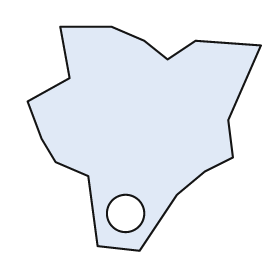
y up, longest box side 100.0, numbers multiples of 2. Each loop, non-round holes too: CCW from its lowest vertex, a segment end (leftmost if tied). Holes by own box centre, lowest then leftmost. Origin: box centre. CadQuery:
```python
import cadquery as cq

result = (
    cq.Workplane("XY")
    .moveTo(-2.0, -48.0)
    .lineTo(14.0, -24.0)
    .lineTo(26.0, -14.0)
    .lineTo(38.0, -8.0)
    .lineTo(36.0, 8.0)
    .lineTo(50.0, 40.0)
    .lineTo(22.0, 42.0)
    .lineTo(10.0, 34.0)
    .lineTo(0.0, 42.0)
    .lineTo(-14.0, 48.0)
    .lineTo(-36.0, 48.0)
    .lineTo(-32.0, 26.0)
    .lineTo(-50.0, 16.0)
    .lineTo(-44.0, 0.0)
    .lineTo(-38.0, -10.0)
    .lineTo(-24.0, -16.0)
    .lineTo(-20.0, -46.0)
    .close()
    .moveTo(-8.0, -32.0)
    .circle(8.0)
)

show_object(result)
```